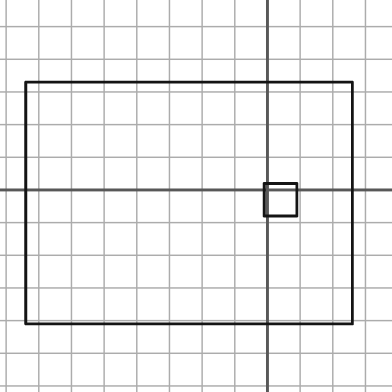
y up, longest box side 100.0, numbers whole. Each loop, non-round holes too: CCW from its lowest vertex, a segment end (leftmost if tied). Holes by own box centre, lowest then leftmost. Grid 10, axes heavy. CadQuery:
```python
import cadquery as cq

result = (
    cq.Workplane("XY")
    .moveTo(-74.0, -41.0)
    .lineTo(26.0, -41.0)
    .lineTo(26.0, 33.0)
    .lineTo(-74.0, 33.0)
    .close()
    .moveTo(-1.0, -8.0)
    .lineTo(9.0, -8.0)
    .lineTo(9.0, 2.0)
    .lineTo(-1.0, 2.0)
    .close()
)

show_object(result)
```